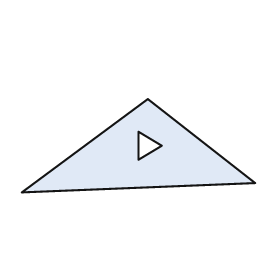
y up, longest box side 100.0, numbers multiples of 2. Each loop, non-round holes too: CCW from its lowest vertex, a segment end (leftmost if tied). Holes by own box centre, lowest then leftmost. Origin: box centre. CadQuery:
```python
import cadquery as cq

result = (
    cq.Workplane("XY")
    .moveTo(-50.0, -20.0)
    .lineTo(50.0, -16.0)
    .lineTo(4.0, 20.0)
    .close()
    .moveTo(0.0, -6.0)
    .lineTo(10.0, 0.0)
    .lineTo(0.0, 6.0)
    .close()
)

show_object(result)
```